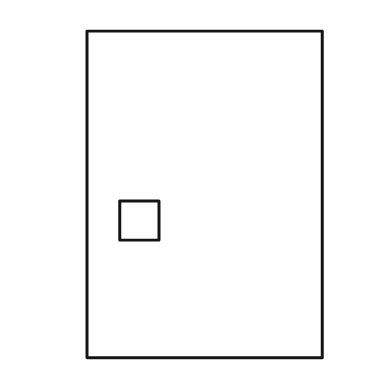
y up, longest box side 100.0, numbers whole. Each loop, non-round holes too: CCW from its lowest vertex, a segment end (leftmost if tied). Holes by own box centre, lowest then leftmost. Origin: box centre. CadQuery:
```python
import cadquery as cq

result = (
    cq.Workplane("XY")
    .moveTo(-36.0, -50.0)
    .lineTo(36.0, -50.0)
    .lineTo(36.0, 50.0)
    .lineTo(-36.0, 50.0)
    .close()
    .moveTo(-26.0, -14.0)
    .lineTo(-14.0, -14.0)
    .lineTo(-14.0, -2.0)
    .lineTo(-26.0, -2.0)
    .close()
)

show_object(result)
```